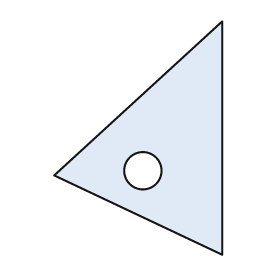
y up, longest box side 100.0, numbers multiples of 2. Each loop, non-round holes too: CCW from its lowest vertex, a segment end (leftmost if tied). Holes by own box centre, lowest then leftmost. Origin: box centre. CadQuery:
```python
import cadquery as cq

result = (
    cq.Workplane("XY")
    .moveTo(36.0, -50.0)
    .lineTo(36.0, 50.0)
    .lineTo(-36.0, -16.0)
    .close()
    .moveTo(2.0, -14.0)
    .circle(8.0)
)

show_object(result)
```